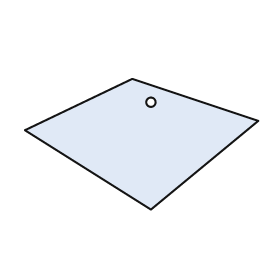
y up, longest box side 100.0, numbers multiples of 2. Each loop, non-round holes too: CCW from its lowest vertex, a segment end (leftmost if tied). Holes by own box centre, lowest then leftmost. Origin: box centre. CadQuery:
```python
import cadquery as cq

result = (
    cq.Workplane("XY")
    .moveTo(4.0, -28.0)
    .lineTo(50.0, 10.0)
    .lineTo(-4.0, 28.0)
    .lineTo(-50.0, 6.0)
    .close()
    .moveTo(4.0, 18.0)
    .circle(2.0)
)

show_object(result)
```